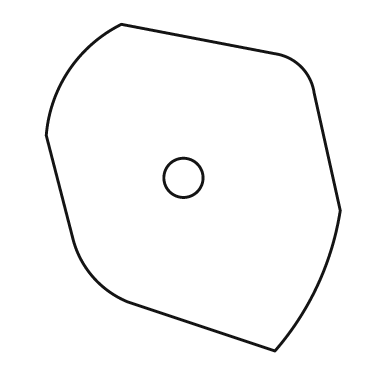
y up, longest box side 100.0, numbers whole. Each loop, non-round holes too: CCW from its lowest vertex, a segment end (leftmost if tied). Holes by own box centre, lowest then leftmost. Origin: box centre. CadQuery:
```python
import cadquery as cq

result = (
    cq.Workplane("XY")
    .moveTo(25.0, -50.0)
    .threePointArc((38.0, -30.0), (45.0, -7.0))
    .lineTo(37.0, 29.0)
    .threePointArc((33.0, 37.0), (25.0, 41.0))
    .lineTo(-22.0, 50.0)
    .threePointArc((-38.0, 36.0), (-45.0, 16.0))
    .lineTo(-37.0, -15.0)
    .threePointArc((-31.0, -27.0), (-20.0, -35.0))
    .close()
    .moveTo(-3.0, 3.0)
    .circle(6.0)
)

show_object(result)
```